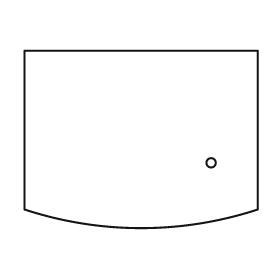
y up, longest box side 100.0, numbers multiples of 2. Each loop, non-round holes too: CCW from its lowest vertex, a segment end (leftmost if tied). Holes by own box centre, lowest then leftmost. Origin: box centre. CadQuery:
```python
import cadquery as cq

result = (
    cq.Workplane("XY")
    .moveTo(-50.0, -30.0)
    .threePointArc((0.0, -38.0), (50.0, -30.0))
    .lineTo(50.0, 38.0)
    .lineTo(-50.0, 38.0)
    .close()
    .moveTo(30.0, -10.0)
    .circle(2.0)
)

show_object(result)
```